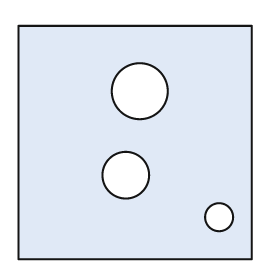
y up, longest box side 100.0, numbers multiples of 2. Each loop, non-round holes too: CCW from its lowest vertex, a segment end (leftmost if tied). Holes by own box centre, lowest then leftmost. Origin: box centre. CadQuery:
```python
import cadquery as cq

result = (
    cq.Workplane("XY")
    .moveTo(-50.0, -50.0)
    .lineTo(50.0, -50.0)
    .lineTo(50.0, 50.0)
    .lineTo(-50.0, 50.0)
    .close()
    .moveTo(36.0, -32.0)
    .circle(6.0)
    .moveTo(-4.0, -14.0)
    .circle(10.0)
    .moveTo(2.0, 22.0)
    .circle(12.0)
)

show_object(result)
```